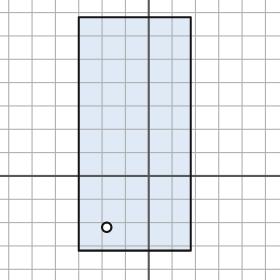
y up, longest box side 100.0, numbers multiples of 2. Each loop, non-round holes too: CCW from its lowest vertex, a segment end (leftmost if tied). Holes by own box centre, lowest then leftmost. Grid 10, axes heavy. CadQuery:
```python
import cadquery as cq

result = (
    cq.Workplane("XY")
    .moveTo(-30.0, -32.0)
    .lineTo(18.0, -32.0)
    .lineTo(18.0, 68.0)
    .lineTo(-30.0, 68.0)
    .close()
    .moveTo(-18.0, -22.0)
    .circle(2.0)
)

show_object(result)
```